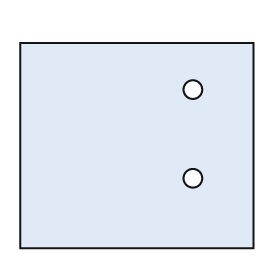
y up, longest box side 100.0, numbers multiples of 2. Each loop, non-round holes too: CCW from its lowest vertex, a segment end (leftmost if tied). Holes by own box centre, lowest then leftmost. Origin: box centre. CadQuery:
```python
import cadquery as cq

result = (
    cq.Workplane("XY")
    .moveTo(-50.0, -44.0)
    .lineTo(50.0, -44.0)
    .lineTo(50.0, 44.0)
    .lineTo(-50.0, 44.0)
    .close()
    .moveTo(24.0, -14.0)
    .circle(4.0)
    .moveTo(24.0, 24.0)
    .circle(4.0)
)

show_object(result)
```